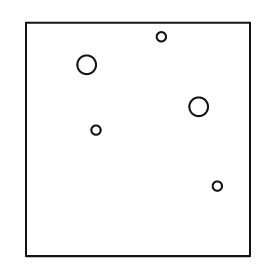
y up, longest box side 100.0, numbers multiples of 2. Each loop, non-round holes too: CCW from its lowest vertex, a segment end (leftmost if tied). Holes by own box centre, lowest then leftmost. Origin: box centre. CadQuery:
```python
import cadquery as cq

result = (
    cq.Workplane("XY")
    .moveTo(-48.0, -50.0)
    .lineTo(48.0, -50.0)
    .lineTo(48.0, 50.0)
    .lineTo(-48.0, 50.0)
    .close()
    .moveTo(34.0, -20.0)
    .circle(2.0)
    .moveTo(-18.0, 4.0)
    .circle(2.0)
    .moveTo(26.0, 14.0)
    .circle(4.0)
    .moveTo(-22.0, 32.0)
    .circle(4.0)
    .moveTo(10.0, 44.0)
    .circle(2.0)
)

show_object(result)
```